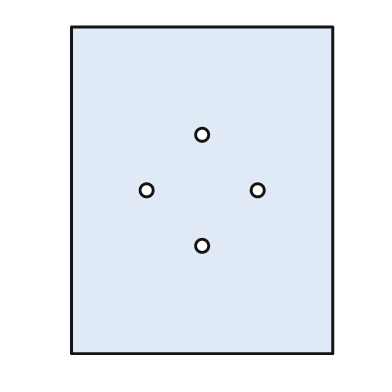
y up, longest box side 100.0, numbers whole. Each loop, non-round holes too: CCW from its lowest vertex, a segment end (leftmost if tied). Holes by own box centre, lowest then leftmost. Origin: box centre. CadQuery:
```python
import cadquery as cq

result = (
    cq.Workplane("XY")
    .moveTo(-40.0, -50.0)
    .lineTo(40.0, -50.0)
    .lineTo(40.0, 50.0)
    .lineTo(-40.0, 50.0)
    .close()
    .moveTo(0.0, -17.0)
    .circle(2.0)
    .moveTo(-17.0, 0.0)
    .circle(2.0)
    .moveTo(17.0, 0.0)
    .circle(2.0)
    .moveTo(0.0, 17.0)
    .circle(2.0)
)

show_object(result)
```